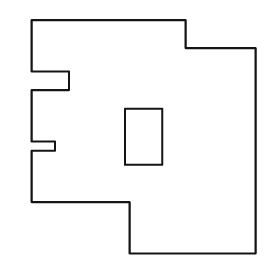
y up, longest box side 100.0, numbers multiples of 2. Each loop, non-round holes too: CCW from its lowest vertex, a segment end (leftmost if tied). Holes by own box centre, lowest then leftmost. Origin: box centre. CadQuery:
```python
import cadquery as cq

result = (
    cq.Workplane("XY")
    .moveTo(-6.0, -50.0)
    .lineTo(48.0, -50.0)
    .lineTo(48.0, 38.0)
    .lineTo(18.0, 38.0)
    .lineTo(18.0, 50.0)
    .lineTo(-48.0, 50.0)
    .lineTo(-48.0, 28.0)
    .lineTo(-32.0, 28.0)
    .lineTo(-32.0, 20.0)
    .lineTo(-48.0, 20.0)
    .lineTo(-48.0, -2.0)
    .lineTo(-38.0, -2.0)
    .lineTo(-38.0, -6.0)
    .lineTo(-48.0, -6.0)
    .lineTo(-48.0, -28.0)
    .lineTo(-6.0, -28.0)
    .close()
    .moveTo(-8.0, -12.0)
    .lineTo(8.0, -12.0)
    .lineTo(8.0, 12.0)
    .lineTo(-8.0, 12.0)
    .close()
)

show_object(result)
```